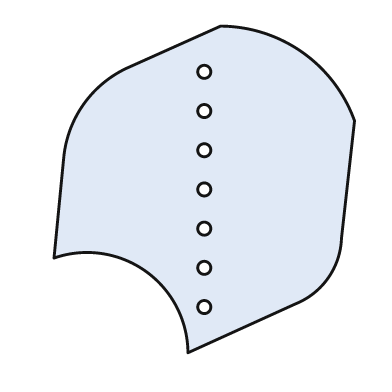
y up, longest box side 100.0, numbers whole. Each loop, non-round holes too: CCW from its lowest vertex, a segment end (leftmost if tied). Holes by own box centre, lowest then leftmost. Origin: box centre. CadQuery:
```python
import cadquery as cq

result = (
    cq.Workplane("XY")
    .moveTo(-5.0, -50.0)
    .lineTo(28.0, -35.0)
    .threePointArc((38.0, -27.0), (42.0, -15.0))
    .lineTo(46.0, 21.0)
    .threePointArc((30.0, 42.0), (5.0, 50.0))
    .lineTo(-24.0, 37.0)
    .threePointArc((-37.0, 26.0), (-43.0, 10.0))
    .lineTo(-46.0, -21.0)
    .threePointArc((-18.0, -25.0), (-5.0, -50.0))
    .close()
    .moveTo(0.0, -36.0)
    .circle(2.0)
    .moveTo(0.0, -24.0)
    .circle(2.0)
    .moveTo(0.0, -12.0)
    .circle(2.0)
    .moveTo(0.0, 0.0)
    .circle(2.0)
    .moveTo(0.0, 12.0)
    .circle(2.0)
    .moveTo(0.0, 24.0)
    .circle(2.0)
    .moveTo(0.0, 36.0)
    .circle(2.0)
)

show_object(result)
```